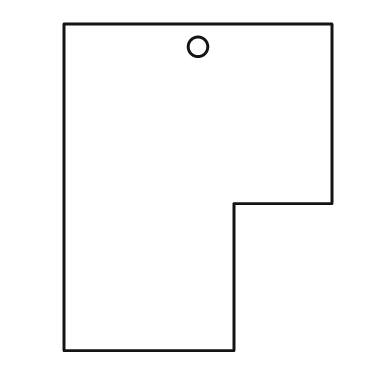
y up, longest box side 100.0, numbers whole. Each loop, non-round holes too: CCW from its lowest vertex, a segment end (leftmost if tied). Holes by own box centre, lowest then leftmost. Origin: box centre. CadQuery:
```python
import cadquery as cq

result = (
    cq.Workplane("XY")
    .moveTo(-41.0, -50.0)
    .lineTo(11.0, -50.0)
    .lineTo(11.0, -5.0)
    .lineTo(41.0, -5.0)
    .lineTo(41.0, 50.0)
    .lineTo(-41.0, 50.0)
    .close()
    .moveTo(0.0, 43.0)
    .circle(3.0)
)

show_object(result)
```